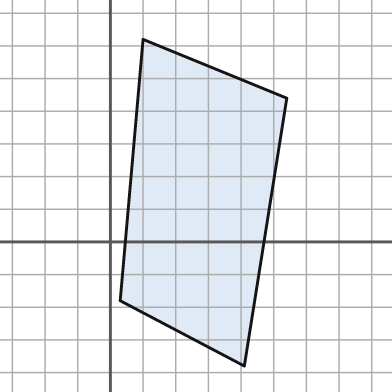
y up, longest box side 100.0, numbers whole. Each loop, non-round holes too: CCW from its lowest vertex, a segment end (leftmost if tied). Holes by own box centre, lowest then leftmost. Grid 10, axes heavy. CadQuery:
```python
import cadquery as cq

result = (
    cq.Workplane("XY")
    .moveTo(41.0, -38.0)
    .lineTo(54.0, 44.0)
    .lineTo(10.0, 62.0)
    .lineTo(3.0, -18.0)
    .close()
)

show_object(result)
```